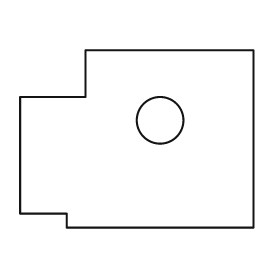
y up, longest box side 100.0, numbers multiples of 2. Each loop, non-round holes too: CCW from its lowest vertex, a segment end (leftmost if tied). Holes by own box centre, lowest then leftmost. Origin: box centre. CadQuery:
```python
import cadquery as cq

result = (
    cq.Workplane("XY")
    .moveTo(-30.0, -38.0)
    .lineTo(50.0, -38.0)
    .lineTo(50.0, 38.0)
    .lineTo(-22.0, 38.0)
    .lineTo(-22.0, 18.0)
    .lineTo(-50.0, 18.0)
    .lineTo(-50.0, -32.0)
    .lineTo(-30.0, -32.0)
    .close()
    .moveTo(10.0, 8.0)
    .circle(10.0)
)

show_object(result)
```